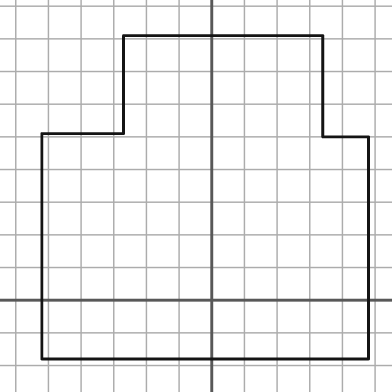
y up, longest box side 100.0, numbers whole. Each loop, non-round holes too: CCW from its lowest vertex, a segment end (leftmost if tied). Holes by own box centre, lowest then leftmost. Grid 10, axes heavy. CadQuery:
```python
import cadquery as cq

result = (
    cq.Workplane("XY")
    .moveTo(-52.0, -18.0)
    .lineTo(48.0, -18.0)
    .lineTo(48.0, 50.0)
    .lineTo(34.0, 50.0)
    .lineTo(34.0, 81.0)
    .lineTo(-27.0, 81.0)
    .lineTo(-27.0, 51.0)
    .lineTo(-52.0, 51.0)
    .close()
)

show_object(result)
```